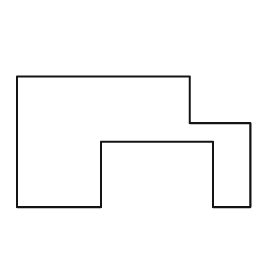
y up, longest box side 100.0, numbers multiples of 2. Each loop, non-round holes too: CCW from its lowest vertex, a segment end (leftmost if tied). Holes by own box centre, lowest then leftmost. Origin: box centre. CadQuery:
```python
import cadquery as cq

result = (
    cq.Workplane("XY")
    .moveTo(-50.0, -28.0)
    .lineTo(-14.0, -28.0)
    .lineTo(-14.0, 0.0)
    .lineTo(34.0, 0.0)
    .lineTo(34.0, -28.0)
    .lineTo(50.0, -28.0)
    .lineTo(50.0, 8.0)
    .lineTo(24.0, 8.0)
    .lineTo(24.0, 28.0)
    .lineTo(-50.0, 28.0)
    .close()
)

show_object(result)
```